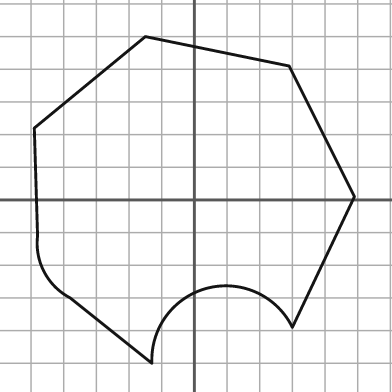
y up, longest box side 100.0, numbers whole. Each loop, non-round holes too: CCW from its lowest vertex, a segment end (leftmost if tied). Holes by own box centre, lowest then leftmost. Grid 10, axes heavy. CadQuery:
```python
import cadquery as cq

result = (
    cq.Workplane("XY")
    .moveTo(-13.0, -50.0)
    .threePointArc((4.0, -27.0), (30.0, -39.0))
    .lineTo(49.0, 1.0)
    .lineTo(29.0, 41.0)
    .lineTo(-15.0, 50.0)
    .lineTo(-49.0, 22.0)
    .lineTo(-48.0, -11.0)
    .threePointArc((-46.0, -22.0), (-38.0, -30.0))
    .close()
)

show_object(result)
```